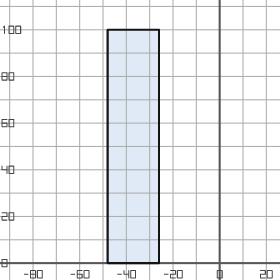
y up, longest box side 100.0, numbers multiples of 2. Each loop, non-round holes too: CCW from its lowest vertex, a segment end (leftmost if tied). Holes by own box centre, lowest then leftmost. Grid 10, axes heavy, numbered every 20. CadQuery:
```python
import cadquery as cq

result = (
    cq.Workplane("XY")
    .moveTo(-48.0, 0.0)
    .lineTo(-26.0, 0.0)
    .lineTo(-26.0, 100.0)
    .lineTo(-48.0, 100.0)
    .close()
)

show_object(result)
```